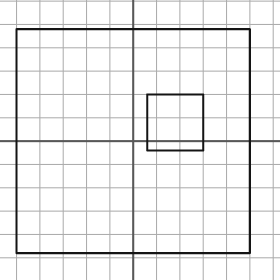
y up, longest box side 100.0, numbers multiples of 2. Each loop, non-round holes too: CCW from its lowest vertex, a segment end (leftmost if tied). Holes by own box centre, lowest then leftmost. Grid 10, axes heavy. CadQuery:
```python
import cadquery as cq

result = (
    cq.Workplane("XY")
    .moveTo(-50.0, -48.0)
    .lineTo(50.0, -48.0)
    .lineTo(50.0, 48.0)
    .lineTo(-50.0, 48.0)
    .close()
    .moveTo(6.0, -4.0)
    .lineTo(30.0, -4.0)
    .lineTo(30.0, 20.0)
    .lineTo(6.0, 20.0)
    .close()
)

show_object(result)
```